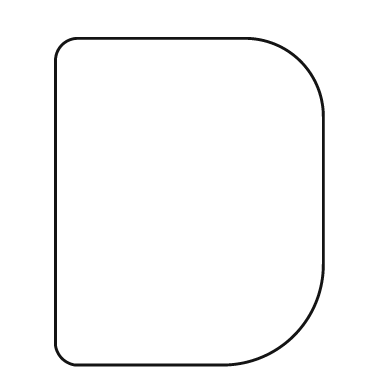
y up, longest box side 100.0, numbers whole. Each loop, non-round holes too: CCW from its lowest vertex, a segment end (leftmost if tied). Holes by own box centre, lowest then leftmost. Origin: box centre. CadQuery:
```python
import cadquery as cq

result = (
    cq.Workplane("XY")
    .moveTo(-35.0, -50.0)
    .lineTo(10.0, -50.0)
    .threePointArc((32.0, -41.0), (41.0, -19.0))
    .lineTo(41.0, 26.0)
    .threePointArc((34.0, 43.0), (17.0, 50.0))
    .lineTo(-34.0, 50.0)
    .threePointArc((-39.0, 48.0), (-41.0, 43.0))
    .lineTo(-41.0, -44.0)
    .threePointArc((-39.0, -48.0), (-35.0, -50.0))
    .close()
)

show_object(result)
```